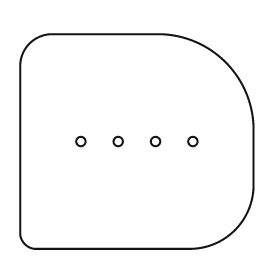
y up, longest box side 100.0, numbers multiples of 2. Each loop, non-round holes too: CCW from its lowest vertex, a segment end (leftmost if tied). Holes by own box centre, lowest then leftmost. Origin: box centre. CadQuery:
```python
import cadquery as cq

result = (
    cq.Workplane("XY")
    .moveTo(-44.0, -46.0)
    .lineTo(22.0, -46.0)
    .threePointArc((42.0, -38.0), (50.0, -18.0))
    .lineTo(50.0, 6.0)
    .threePointArc((38.0, 34.0), (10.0, 46.0))
    .lineTo(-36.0, 46.0)
    .threePointArc((-46.0, 42.0), (-50.0, 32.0))
    .lineTo(-50.0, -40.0)
    .threePointArc((-48.0, -44.0), (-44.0, -46.0))
    .close()
    .moveTo(-24.0, 0.0)
    .circle(2.0)
    .moveTo(-8.0, 0.0)
    .circle(2.0)
    .moveTo(8.0, 0.0)
    .circle(2.0)
    .moveTo(24.0, 0.0)
    .circle(2.0)
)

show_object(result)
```